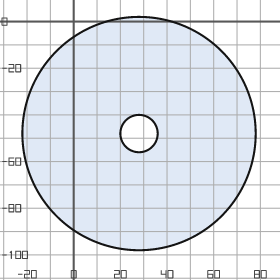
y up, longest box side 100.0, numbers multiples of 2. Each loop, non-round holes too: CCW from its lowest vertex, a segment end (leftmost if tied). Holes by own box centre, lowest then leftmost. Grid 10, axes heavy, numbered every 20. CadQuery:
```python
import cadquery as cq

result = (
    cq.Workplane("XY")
    .moveTo(28.0, -48.0)
    .circle(50.0)
    .moveTo(28.0, -48.0)
    .circle(8.0)
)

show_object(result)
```